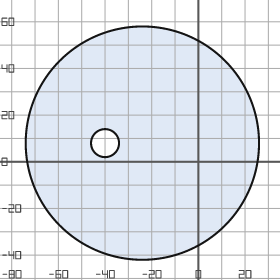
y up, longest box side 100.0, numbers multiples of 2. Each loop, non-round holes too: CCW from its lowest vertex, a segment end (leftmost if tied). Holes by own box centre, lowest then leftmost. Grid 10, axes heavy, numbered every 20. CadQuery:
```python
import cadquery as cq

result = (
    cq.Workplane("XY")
    .moveTo(-24.0, 8.0)
    .circle(50.0)
    .moveTo(-40.0, 8.0)
    .circle(6.0)
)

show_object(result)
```